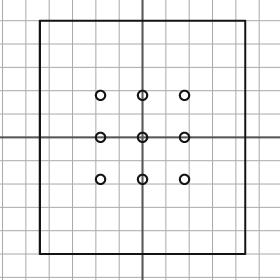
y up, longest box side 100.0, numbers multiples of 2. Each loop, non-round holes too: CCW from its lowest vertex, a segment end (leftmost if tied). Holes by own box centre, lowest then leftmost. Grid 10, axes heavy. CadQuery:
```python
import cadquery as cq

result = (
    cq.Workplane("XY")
    .moveTo(-44.0, -50.0)
    .lineTo(44.0, -50.0)
    .lineTo(44.0, 50.0)
    .lineTo(-44.0, 50.0)
    .close()
    .moveTo(-18.0, -18.0)
    .circle(2.0)
    .moveTo(0.0, -18.0)
    .circle(2.0)
    .moveTo(18.0, -18.0)
    .circle(2.0)
    .moveTo(-18.0, 0.0)
    .circle(2.0)
    .moveTo(0.0, 0.0)
    .circle(2.0)
    .moveTo(18.0, 0.0)
    .circle(2.0)
    .moveTo(-18.0, 18.0)
    .circle(2.0)
    .moveTo(0.0, 18.0)
    .circle(2.0)
    .moveTo(18.0, 18.0)
    .circle(2.0)
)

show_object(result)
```